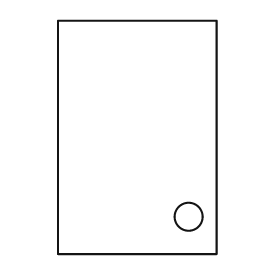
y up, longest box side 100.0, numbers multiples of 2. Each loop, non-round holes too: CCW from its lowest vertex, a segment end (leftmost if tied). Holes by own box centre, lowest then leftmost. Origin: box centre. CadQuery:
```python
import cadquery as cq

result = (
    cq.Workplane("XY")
    .moveTo(-34.0, -50.0)
    .lineTo(34.0, -50.0)
    .lineTo(34.0, 50.0)
    .lineTo(-34.0, 50.0)
    .close()
    .moveTo(22.0, -34.0)
    .circle(6.0)
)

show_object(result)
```